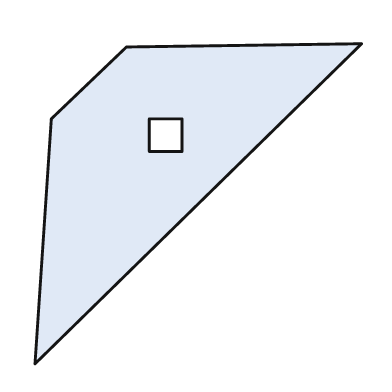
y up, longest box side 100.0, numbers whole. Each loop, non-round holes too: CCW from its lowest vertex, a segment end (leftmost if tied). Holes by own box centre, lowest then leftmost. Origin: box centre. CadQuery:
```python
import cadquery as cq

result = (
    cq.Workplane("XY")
    .moveTo(-50.0, -49.0)
    .lineTo(50.0, 49.0)
    .lineTo(-22.0, 48.0)
    .lineTo(-45.0, 26.0)
    .close()
    .moveTo(-15.0, 16.0)
    .lineTo(-5.0, 16.0)
    .lineTo(-5.0, 26.0)
    .lineTo(-15.0, 26.0)
    .close()
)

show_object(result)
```